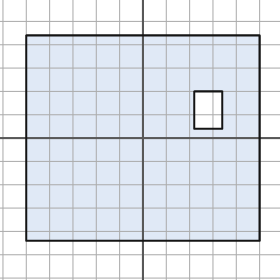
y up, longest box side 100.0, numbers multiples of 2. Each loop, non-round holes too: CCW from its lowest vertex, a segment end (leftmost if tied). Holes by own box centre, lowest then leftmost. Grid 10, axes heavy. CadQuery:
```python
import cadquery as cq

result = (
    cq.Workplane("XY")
    .moveTo(-50.0, -44.0)
    .lineTo(50.0, -44.0)
    .lineTo(50.0, 44.0)
    .lineTo(-50.0, 44.0)
    .close()
    .moveTo(22.0, 4.0)
    .lineTo(34.0, 4.0)
    .lineTo(34.0, 20.0)
    .lineTo(22.0, 20.0)
    .close()
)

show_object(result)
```